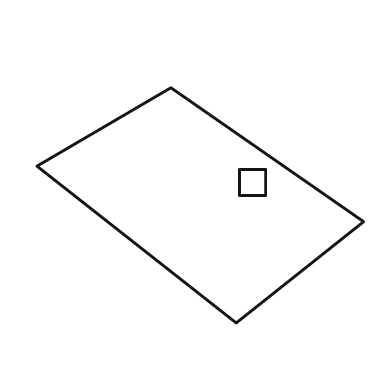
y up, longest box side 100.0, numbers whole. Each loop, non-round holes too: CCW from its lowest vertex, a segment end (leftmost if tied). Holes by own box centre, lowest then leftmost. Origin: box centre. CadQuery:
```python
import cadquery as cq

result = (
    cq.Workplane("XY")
    .moveTo(11.0, -36.0)
    .lineTo(50.0, -5.0)
    .lineTo(-9.0, 36.0)
    .lineTo(-50.0, 12.0)
    .close()
    .moveTo(12.0, 3.0)
    .lineTo(20.0, 3.0)
    .lineTo(20.0, 11.0)
    .lineTo(12.0, 11.0)
    .close()
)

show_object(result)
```